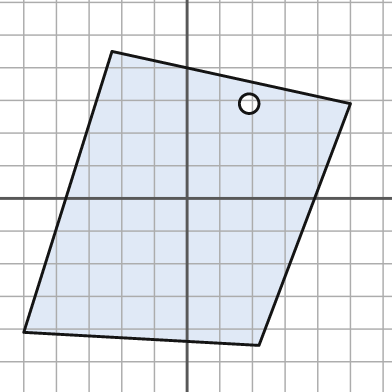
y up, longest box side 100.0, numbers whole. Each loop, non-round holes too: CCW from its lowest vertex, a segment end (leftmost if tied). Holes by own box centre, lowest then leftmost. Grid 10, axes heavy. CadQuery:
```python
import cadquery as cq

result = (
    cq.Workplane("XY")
    .moveTo(22.0, -45.0)
    .lineTo(50.0, 29.0)
    .lineTo(-23.0, 45.0)
    .lineTo(-50.0, -41.0)
    .close()
    .moveTo(19.0, 29.0)
    .circle(3.0)
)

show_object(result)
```